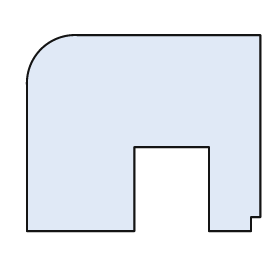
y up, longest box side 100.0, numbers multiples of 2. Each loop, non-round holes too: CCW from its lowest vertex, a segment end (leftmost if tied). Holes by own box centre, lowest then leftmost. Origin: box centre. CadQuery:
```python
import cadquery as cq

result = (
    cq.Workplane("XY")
    .moveTo(-50.0, -42.0)
    .lineTo(-4.0, -42.0)
    .lineTo(-4.0, -6.0)
    .lineTo(28.0, -6.0)
    .lineTo(28.0, -42.0)
    .lineTo(46.0, -42.0)
    .lineTo(46.0, -36.0)
    .lineTo(50.0, -36.0)
    .lineTo(50.0, 42.0)
    .lineTo(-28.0, 42.0)
    .threePointArc((-44.0, 36.0), (-50.0, 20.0))
    .close()
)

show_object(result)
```